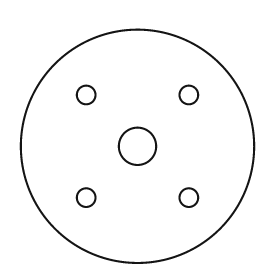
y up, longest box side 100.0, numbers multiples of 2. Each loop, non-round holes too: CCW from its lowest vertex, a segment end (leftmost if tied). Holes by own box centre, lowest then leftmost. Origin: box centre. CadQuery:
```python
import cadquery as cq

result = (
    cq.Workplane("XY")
    .moveTo(0.0, 0.0)
    .circle(50.0)
    .moveTo(-22.0, -22.0)
    .circle(4.0)
    .moveTo(22.0, -22.0)
    .circle(4.0)
    .moveTo(0.0, 0.0)
    .circle(8.0)
    .moveTo(-22.0, 22.0)
    .circle(4.0)
    .moveTo(22.0, 22.0)
    .circle(4.0)
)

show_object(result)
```